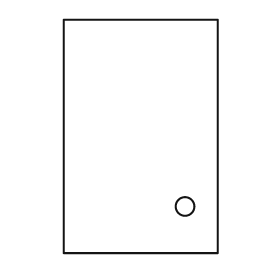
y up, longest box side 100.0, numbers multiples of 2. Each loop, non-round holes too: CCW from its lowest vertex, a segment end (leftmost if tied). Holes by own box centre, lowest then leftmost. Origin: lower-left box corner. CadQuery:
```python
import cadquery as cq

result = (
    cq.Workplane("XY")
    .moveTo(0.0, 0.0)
    .lineTo(66.0, 0.0)
    .lineTo(66.0, 100.0)
    .lineTo(0.0, 100.0)
    .close()
    .moveTo(52.0, 20.0)
    .circle(4.0)
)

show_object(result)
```